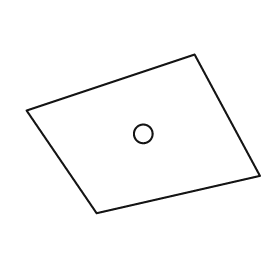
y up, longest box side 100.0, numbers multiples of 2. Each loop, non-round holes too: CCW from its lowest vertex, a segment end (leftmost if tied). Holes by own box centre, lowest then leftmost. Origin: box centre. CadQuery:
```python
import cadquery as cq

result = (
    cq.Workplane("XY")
    .moveTo(-20.0, -34.0)
    .lineTo(50.0, -18.0)
    .lineTo(22.0, 34.0)
    .lineTo(-50.0, 10.0)
    .close()
    .moveTo(0.0, 0.0)
    .circle(4.0)
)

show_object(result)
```